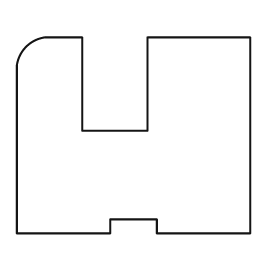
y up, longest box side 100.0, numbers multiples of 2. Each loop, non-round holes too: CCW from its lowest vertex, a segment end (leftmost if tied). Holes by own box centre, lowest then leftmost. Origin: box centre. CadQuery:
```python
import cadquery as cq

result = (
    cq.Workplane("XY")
    .moveTo(-50.0, -42.0)
    .lineTo(-10.0, -42.0)
    .lineTo(-10.0, -36.0)
    .lineTo(10.0, -36.0)
    .lineTo(10.0, -42.0)
    .lineTo(50.0, -42.0)
    .lineTo(50.0, 42.0)
    .lineTo(6.0, 42.0)
    .lineTo(6.0, 2.0)
    .lineTo(-22.0, 2.0)
    .lineTo(-22.0, 42.0)
    .lineTo(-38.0, 42.0)
    .threePointArc((-46.0, 38.0), (-50.0, 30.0))
    .close()
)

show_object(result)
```